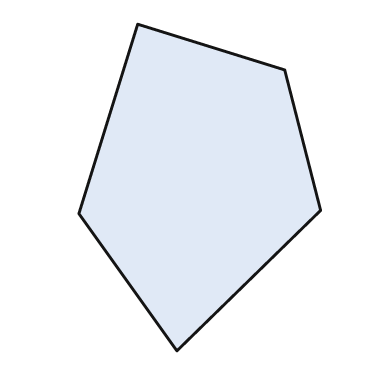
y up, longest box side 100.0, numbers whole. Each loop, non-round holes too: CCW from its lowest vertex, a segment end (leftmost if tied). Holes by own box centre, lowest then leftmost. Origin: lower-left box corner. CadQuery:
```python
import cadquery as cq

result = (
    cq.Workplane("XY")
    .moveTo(30.0, 0.0)
    .lineTo(74.0, 43.0)
    .lineTo(63.0, 86.0)
    .lineTo(18.0, 100.0)
    .lineTo(0.0, 42.0)
    .close()
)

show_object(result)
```